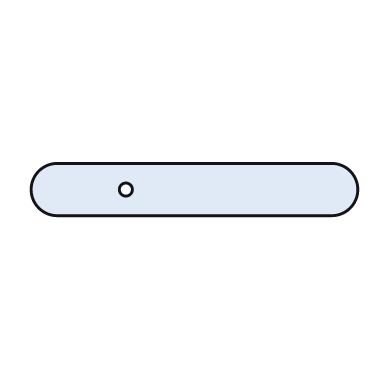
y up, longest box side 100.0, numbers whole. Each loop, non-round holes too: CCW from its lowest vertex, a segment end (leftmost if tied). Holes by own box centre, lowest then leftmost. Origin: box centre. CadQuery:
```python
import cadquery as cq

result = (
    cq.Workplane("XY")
    .moveTo(-42.0, -8.0)
    .lineTo(42.0, -8.0)
    .threePointArc((50.0, 0.0), (42.0, 8.0))
    .lineTo(-42.0, 8.0)
    .threePointArc((-50.0, 0.0), (-42.0, -8.0))
    .close()
    .moveTo(-21.0, 0.0)
    .circle(2.0)
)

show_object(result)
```